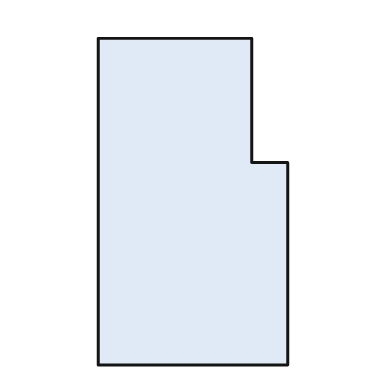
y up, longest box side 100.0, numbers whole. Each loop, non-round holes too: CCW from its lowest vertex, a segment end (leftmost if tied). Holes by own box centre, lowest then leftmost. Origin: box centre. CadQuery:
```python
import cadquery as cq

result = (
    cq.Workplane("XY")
    .moveTo(-29.0, -50.0)
    .lineTo(29.0, -50.0)
    .lineTo(29.0, 12.0)
    .lineTo(18.0, 12.0)
    .lineTo(18.0, 50.0)
    .lineTo(-29.0, 50.0)
    .close()
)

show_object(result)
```